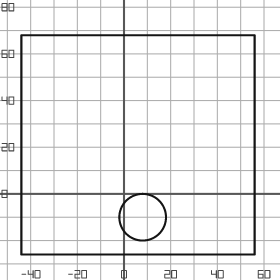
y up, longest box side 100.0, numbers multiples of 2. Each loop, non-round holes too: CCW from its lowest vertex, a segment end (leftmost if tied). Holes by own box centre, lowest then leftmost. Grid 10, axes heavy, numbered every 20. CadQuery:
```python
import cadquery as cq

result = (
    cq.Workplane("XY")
    .moveTo(-44.0, -26.0)
    .lineTo(56.0, -26.0)
    .lineTo(56.0, 68.0)
    .lineTo(-44.0, 68.0)
    .close()
    .moveTo(8.0, -10.0)
    .circle(10.0)
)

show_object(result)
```